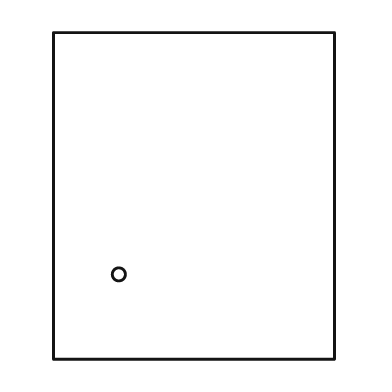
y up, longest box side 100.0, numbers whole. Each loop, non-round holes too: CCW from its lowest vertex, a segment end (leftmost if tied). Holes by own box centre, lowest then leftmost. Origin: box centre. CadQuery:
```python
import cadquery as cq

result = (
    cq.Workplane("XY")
    .moveTo(-43.0, -50.0)
    .lineTo(43.0, -50.0)
    .lineTo(43.0, 50.0)
    .lineTo(-43.0, 50.0)
    .close()
    .moveTo(-23.0, -24.0)
    .circle(2.0)
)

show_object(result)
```